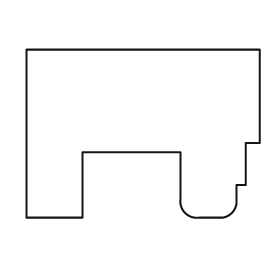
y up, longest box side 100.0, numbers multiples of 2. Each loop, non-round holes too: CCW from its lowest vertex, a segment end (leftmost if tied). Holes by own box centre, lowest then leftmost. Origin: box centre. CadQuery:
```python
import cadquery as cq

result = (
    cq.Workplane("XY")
    .moveTo(-50.0, -36.0)
    .lineTo(-26.0, -36.0)
    .lineTo(-26.0, -8.0)
    .lineTo(16.0, -8.0)
    .lineTo(16.0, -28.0)
    .threePointArc((18.0, -34.0), (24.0, -36.0))
    .lineTo(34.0, -36.0)
    .threePointArc((38.0, -34.0), (40.0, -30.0))
    .lineTo(40.0, -22.0)
    .lineTo(44.0, -22.0)
    .lineTo(44.0, -4.0)
    .lineTo(50.0, -4.0)
    .lineTo(50.0, 36.0)
    .lineTo(-50.0, 36.0)
    .close()
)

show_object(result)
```